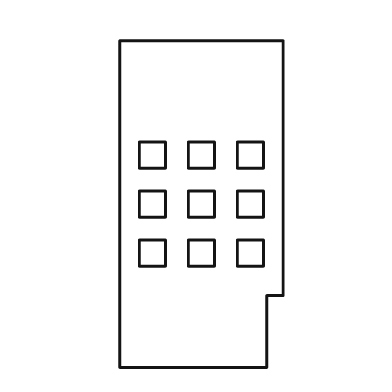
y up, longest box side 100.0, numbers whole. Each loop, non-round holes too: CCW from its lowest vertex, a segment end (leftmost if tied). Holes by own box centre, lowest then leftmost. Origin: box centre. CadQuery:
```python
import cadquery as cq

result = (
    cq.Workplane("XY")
    .moveTo(-25.0, -50.0)
    .lineTo(20.0, -50.0)
    .lineTo(20.0, -28.0)
    .lineTo(25.0, -28.0)
    .lineTo(25.0, 50.0)
    .lineTo(-25.0, 50.0)
    .close()
    .moveTo(-19.0, -19.0)
    .lineTo(-11.0, -19.0)
    .lineTo(-11.0, -11.0)
    .lineTo(-19.0, -11.0)
    .close()
    .moveTo(-4.0, -19.0)
    .lineTo(4.0, -19.0)
    .lineTo(4.0, -11.0)
    .lineTo(-4.0, -11.0)
    .close()
    .moveTo(11.0, -19.0)
    .lineTo(19.0, -19.0)
    .lineTo(19.0, -11.0)
    .lineTo(11.0, -11.0)
    .close()
    .moveTo(-19.0, -4.0)
    .lineTo(-11.0, -4.0)
    .lineTo(-11.0, 4.0)
    .lineTo(-19.0, 4.0)
    .close()
    .moveTo(-4.0, -4.0)
    .lineTo(4.0, -4.0)
    .lineTo(4.0, 4.0)
    .lineTo(-4.0, 4.0)
    .close()
    .moveTo(11.0, -4.0)
    .lineTo(19.0, -4.0)
    .lineTo(19.0, 4.0)
    .lineTo(11.0, 4.0)
    .close()
    .moveTo(-19.0, 11.0)
    .lineTo(-11.0, 11.0)
    .lineTo(-11.0, 19.0)
    .lineTo(-19.0, 19.0)
    .close()
    .moveTo(-4.0, 11.0)
    .lineTo(4.0, 11.0)
    .lineTo(4.0, 19.0)
    .lineTo(-4.0, 19.0)
    .close()
    .moveTo(11.0, 11.0)
    .lineTo(19.0, 11.0)
    .lineTo(19.0, 19.0)
    .lineTo(11.0, 19.0)
    .close()
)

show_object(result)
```